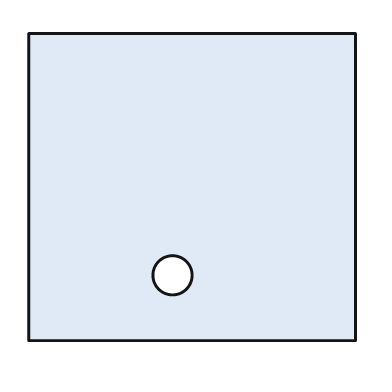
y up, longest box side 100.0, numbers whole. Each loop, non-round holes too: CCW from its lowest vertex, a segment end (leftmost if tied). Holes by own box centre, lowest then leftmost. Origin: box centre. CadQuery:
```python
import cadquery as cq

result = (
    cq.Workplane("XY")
    .moveTo(-50.0, -47.0)
    .lineTo(50.0, -47.0)
    .lineTo(50.0, 47.0)
    .lineTo(-50.0, 47.0)
    .close()
    .moveTo(-6.0, -27.0)
    .circle(6.0)
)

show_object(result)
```